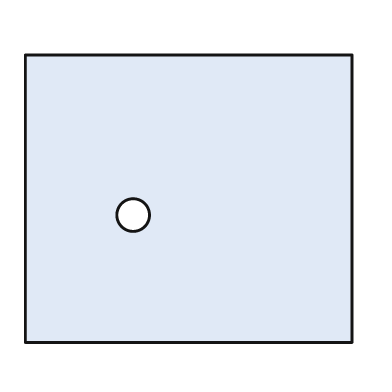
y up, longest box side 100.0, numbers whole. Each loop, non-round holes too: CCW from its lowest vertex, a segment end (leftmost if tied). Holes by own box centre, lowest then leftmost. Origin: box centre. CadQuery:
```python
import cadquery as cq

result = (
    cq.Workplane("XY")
    .moveTo(-50.0, -44.0)
    .lineTo(50.0, -44.0)
    .lineTo(50.0, 44.0)
    .lineTo(-50.0, 44.0)
    .close()
    .moveTo(-17.0, -5.0)
    .circle(5.0)
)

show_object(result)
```